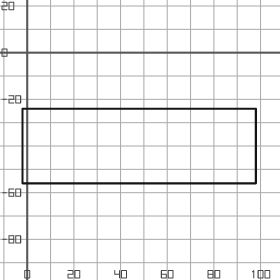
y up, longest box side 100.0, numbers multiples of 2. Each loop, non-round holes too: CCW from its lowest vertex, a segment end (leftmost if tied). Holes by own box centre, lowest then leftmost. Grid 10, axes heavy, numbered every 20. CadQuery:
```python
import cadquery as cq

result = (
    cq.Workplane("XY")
    .moveTo(-2.0, -56.0)
    .lineTo(98.0, -56.0)
    .lineTo(98.0, -24.0)
    .lineTo(-2.0, -24.0)
    .close()
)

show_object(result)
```